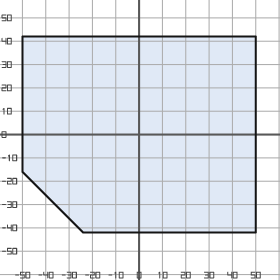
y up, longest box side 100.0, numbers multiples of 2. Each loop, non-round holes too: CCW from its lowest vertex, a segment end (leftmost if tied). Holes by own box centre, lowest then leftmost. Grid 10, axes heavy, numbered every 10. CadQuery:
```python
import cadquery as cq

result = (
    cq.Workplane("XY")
    .moveTo(-24.0, -42.0)
    .lineTo(50.0, -42.0)
    .lineTo(50.0, 42.0)
    .lineTo(-50.0, 42.0)
    .lineTo(-50.0, -16.0)
    .close()
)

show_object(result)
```